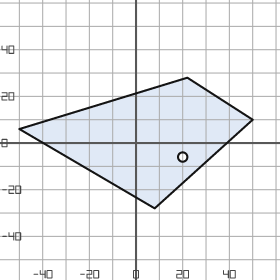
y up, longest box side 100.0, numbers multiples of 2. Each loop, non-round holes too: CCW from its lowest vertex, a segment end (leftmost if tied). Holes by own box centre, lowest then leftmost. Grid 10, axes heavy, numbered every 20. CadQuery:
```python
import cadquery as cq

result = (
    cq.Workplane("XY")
    .moveTo(8.0, -28.0)
    .lineTo(50.0, 10.0)
    .lineTo(22.0, 28.0)
    .lineTo(-50.0, 6.0)
    .close()
    .moveTo(20.0, -6.0)
    .circle(2.0)
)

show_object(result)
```